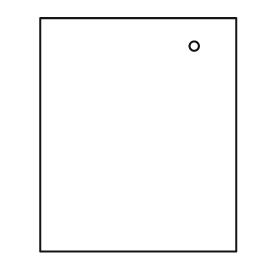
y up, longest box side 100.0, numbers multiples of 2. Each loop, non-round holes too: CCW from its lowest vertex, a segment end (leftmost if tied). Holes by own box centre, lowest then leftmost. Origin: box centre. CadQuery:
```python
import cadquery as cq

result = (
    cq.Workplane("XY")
    .moveTo(-42.0, -50.0)
    .lineTo(42.0, -50.0)
    .lineTo(42.0, 50.0)
    .lineTo(-42.0, 50.0)
    .close()
    .moveTo(24.0, 38.0)
    .circle(2.0)
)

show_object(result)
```